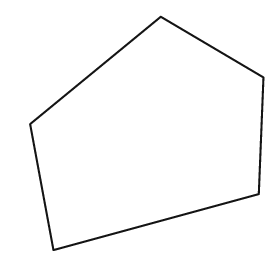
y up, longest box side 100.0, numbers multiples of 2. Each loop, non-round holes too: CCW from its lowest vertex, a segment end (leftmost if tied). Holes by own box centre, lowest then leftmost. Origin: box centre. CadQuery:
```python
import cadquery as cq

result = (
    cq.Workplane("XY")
    .moveTo(-40.0, -50.0)
    .lineTo(48.0, -26.0)
    .lineTo(50.0, 24.0)
    .lineTo(6.0, 50.0)
    .lineTo(-50.0, 4.0)
    .close()
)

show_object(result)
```